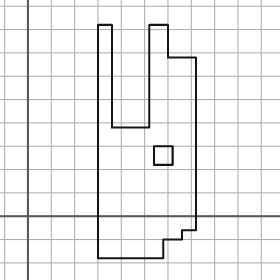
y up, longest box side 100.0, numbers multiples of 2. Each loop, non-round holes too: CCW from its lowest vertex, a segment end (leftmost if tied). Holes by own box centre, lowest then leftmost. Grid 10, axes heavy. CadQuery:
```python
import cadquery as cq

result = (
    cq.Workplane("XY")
    .moveTo(30.0, -18.0)
    .lineTo(58.0, -18.0)
    .lineTo(58.0, -10.0)
    .lineTo(66.0, -10.0)
    .lineTo(66.0, -6.0)
    .lineTo(72.0, -6.0)
    .lineTo(72.0, 68.0)
    .lineTo(60.0, 68.0)
    .lineTo(60.0, 82.0)
    .lineTo(52.0, 82.0)
    .lineTo(52.0, 38.0)
    .lineTo(36.0, 38.0)
    .lineTo(36.0, 82.0)
    .lineTo(30.0, 82.0)
    .close()
    .moveTo(54.0, 22.0)
    .lineTo(62.0, 22.0)
    .lineTo(62.0, 30.0)
    .lineTo(54.0, 30.0)
    .close()
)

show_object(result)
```